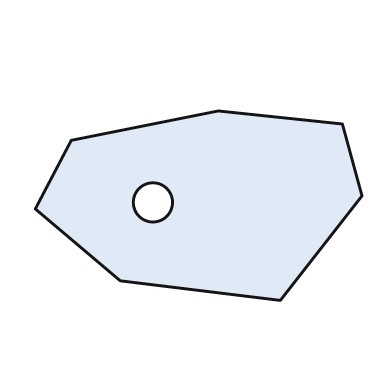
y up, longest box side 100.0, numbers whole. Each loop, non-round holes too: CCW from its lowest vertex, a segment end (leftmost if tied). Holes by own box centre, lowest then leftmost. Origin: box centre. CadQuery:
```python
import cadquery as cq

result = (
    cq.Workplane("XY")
    .moveTo(25.0, -29.0)
    .lineTo(50.0, 3.0)
    .lineTo(44.0, 25.0)
    .lineTo(6.0, 29.0)
    .lineTo(-39.0, 20.0)
    .lineTo(-50.0, -1.0)
    .lineTo(-24.0, -23.0)
    .close()
    .moveTo(-14.0, 1.0)
    .circle(6.0)
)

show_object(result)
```